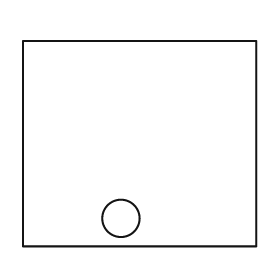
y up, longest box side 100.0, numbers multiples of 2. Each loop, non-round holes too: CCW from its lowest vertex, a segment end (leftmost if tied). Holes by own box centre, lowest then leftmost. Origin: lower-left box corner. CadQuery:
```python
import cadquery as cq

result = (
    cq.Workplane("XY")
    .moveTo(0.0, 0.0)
    .lineTo(100.0, 0.0)
    .lineTo(100.0, 88.0)
    .lineTo(0.0, 88.0)
    .close()
    .moveTo(42.0, 12.0)
    .circle(8.0)
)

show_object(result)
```